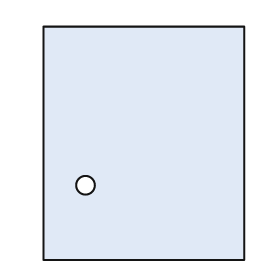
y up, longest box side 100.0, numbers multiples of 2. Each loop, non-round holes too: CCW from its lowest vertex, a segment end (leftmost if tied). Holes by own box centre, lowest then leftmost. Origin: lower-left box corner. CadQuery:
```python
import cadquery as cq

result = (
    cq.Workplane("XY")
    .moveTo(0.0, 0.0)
    .lineTo(86.0, 0.0)
    .lineTo(86.0, 100.0)
    .lineTo(0.0, 100.0)
    .close()
    .moveTo(18.0, 32.0)
    .circle(4.0)
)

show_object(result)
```